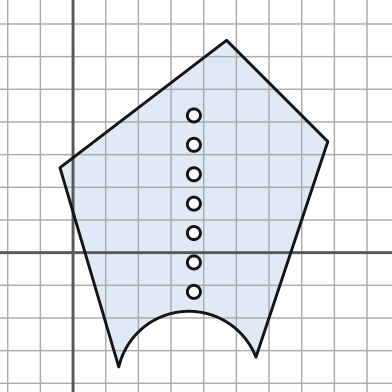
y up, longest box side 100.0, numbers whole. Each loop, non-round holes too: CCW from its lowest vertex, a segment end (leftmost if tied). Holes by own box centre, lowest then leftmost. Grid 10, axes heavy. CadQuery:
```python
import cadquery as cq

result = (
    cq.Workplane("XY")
    .moveTo(14.0, -35.0)
    .threePointArc((34.0, -18.0), (56.0, -32.0))
    .lineTo(78.0, 34.0)
    .lineTo(47.0, 65.0)
    .lineTo(-4.0, 26.0)
    .close()
    .moveTo(37.0, -12.0)
    .circle(2.0)
    .moveTo(37.0, -3.0)
    .circle(2.0)
    .moveTo(37.0, 6.0)
    .circle(2.0)
    .moveTo(37.0, 15.0)
    .circle(2.0)
    .moveTo(37.0, 24.0)
    .circle(2.0)
    .moveTo(37.0, 33.0)
    .circle(2.0)
    .moveTo(37.0, 42.0)
    .circle(2.0)
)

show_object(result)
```